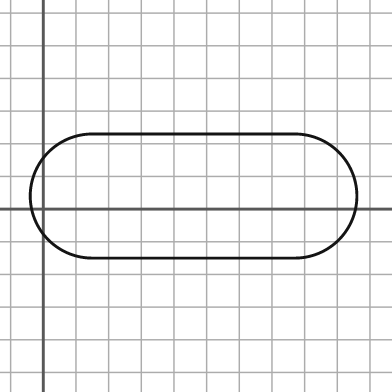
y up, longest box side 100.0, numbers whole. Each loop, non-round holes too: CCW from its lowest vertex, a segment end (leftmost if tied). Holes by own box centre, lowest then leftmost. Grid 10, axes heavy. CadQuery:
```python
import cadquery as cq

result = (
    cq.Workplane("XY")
    .moveTo(15.0, -15.0)
    .lineTo(77.0, -15.0)
    .threePointArc((96.0, 4.0), (77.0, 23.0))
    .lineTo(15.0, 23.0)
    .threePointArc((-4.0, 4.0), (15.0, -15.0))
    .close()
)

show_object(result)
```